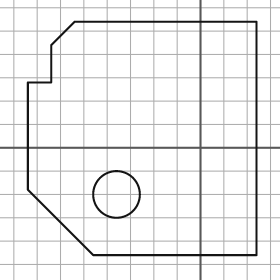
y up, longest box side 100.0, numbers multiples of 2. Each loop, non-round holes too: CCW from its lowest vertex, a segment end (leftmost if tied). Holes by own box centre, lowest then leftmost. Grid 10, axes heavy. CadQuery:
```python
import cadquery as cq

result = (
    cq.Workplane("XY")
    .moveTo(-46.0, -46.0)
    .lineTo(24.0, -46.0)
    .lineTo(24.0, 54.0)
    .lineTo(-54.0, 54.0)
    .lineTo(-64.0, 44.0)
    .lineTo(-64.0, 28.0)
    .lineTo(-74.0, 28.0)
    .lineTo(-74.0, -18.0)
    .close()
    .moveTo(-36.0, -20.0)
    .circle(10.0)
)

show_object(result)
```